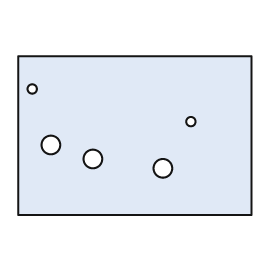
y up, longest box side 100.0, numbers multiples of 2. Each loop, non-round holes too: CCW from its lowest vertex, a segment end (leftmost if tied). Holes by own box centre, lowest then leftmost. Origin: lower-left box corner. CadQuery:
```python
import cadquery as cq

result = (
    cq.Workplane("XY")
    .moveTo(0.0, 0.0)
    .lineTo(100.0, 0.0)
    .lineTo(100.0, 68.0)
    .lineTo(0.0, 68.0)
    .close()
    .moveTo(62.0, 20.0)
    .circle(4.0)
    .moveTo(32.0, 24.0)
    .circle(4.0)
    .moveTo(14.0, 30.0)
    .circle(4.0)
    .moveTo(74.0, 40.0)
    .circle(2.0)
    .moveTo(6.0, 54.0)
    .circle(2.0)
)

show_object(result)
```